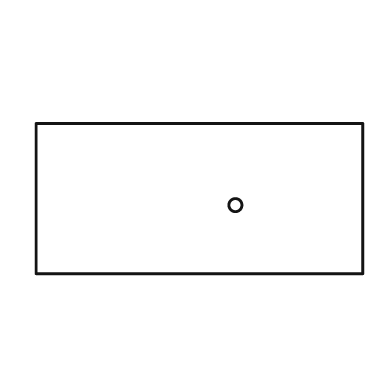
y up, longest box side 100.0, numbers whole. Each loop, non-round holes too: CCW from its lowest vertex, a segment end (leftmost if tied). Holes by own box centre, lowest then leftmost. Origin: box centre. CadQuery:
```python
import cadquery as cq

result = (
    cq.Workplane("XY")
    .moveTo(-50.0, -23.0)
    .lineTo(50.0, -23.0)
    .lineTo(50.0, 23.0)
    .lineTo(-50.0, 23.0)
    .close()
    .moveTo(11.0, -2.0)
    .circle(2.0)
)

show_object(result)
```